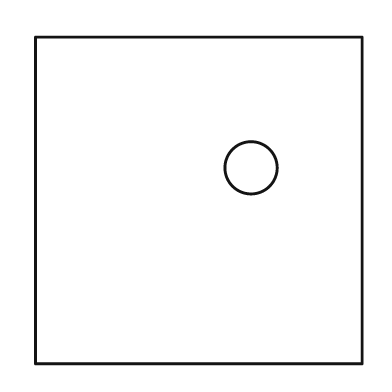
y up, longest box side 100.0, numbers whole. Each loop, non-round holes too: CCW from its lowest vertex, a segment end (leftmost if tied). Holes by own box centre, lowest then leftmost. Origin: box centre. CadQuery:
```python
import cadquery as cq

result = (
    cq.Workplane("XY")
    .moveTo(-50.0, -50.0)
    .lineTo(50.0, -50.0)
    .lineTo(50.0, 50.0)
    .lineTo(-50.0, 50.0)
    .close()
    .moveTo(16.0, 10.0)
    .circle(8.0)
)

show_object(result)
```